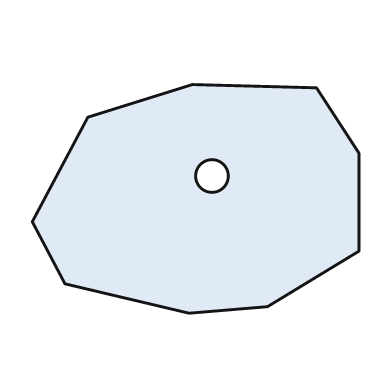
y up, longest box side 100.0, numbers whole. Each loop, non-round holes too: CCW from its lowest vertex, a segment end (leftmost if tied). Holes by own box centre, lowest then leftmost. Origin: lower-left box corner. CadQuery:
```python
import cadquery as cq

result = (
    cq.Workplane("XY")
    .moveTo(48.0, 0.0)
    .lineTo(72.0, 2.0)
    .lineTo(100.0, 19.0)
    .lineTo(100.0, 49.0)
    .lineTo(87.0, 69.0)
    .lineTo(49.0, 70.0)
    .lineTo(17.0, 60.0)
    .lineTo(0.0, 28.0)
    .lineTo(10.0, 9.0)
    .close()
    .moveTo(55.0, 42.0)
    .circle(5.0)
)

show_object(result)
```